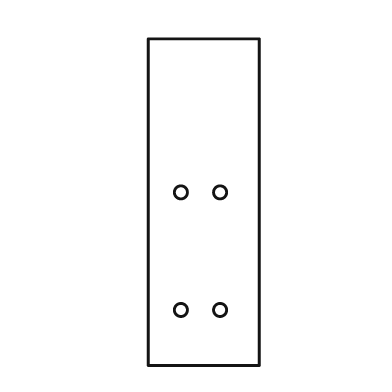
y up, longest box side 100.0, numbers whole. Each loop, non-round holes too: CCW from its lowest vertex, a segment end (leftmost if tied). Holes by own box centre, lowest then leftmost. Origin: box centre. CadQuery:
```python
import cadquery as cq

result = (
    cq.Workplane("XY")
    .moveTo(-17.0, -50.0)
    .lineTo(17.0, -50.0)
    .lineTo(17.0, 50.0)
    .lineTo(-17.0, 50.0)
    .close()
    .moveTo(-7.0, -33.0)
    .circle(2.0)
    .moveTo(5.0, -33.0)
    .circle(2.0)
    .moveTo(-7.0, 3.0)
    .circle(2.0)
    .moveTo(5.0, 3.0)
    .circle(2.0)
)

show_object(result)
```